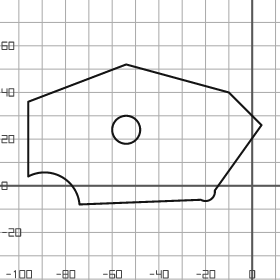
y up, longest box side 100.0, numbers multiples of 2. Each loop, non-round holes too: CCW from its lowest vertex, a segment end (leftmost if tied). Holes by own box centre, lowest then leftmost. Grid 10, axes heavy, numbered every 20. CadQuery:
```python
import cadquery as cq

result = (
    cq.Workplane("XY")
    .moveTo(-74.0, -8.0)
    .lineTo(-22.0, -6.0)
    .threePointArc((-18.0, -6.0), (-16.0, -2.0))
    .lineTo(4.0, 26.0)
    .lineTo(-10.0, 40.0)
    .lineTo(-54.0, 52.0)
    .lineTo(-96.0, 36.0)
    .lineTo(-96.0, 4.0)
    .threePointArc((-82.0, 4.0), (-74.0, -8.0))
    .close()
    .moveTo(-54.0, 24.0)
    .circle(6.0)
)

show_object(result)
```